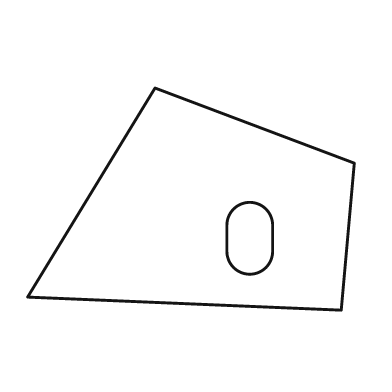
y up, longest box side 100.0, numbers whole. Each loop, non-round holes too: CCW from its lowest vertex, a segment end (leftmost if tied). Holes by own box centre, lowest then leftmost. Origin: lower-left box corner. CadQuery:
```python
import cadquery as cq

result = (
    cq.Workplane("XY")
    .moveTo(96.0, 0.0)
    .lineTo(100.0, 45.0)
    .lineTo(39.0, 68.0)
    .lineTo(0.0, 4.0)
    .close()
    .moveTo(61.0, 18.0)
    .threePointArc((68.0, 11.0), (75.0, 18.0))
    .lineTo(75.0, 26.0)
    .threePointArc((68.0, 33.0), (61.0, 26.0))
    .close()
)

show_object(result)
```